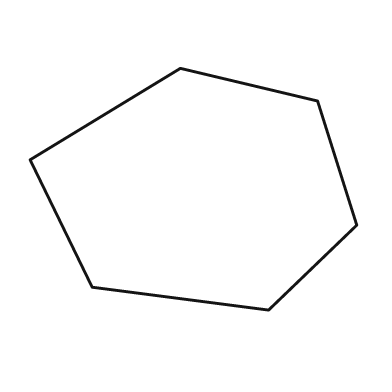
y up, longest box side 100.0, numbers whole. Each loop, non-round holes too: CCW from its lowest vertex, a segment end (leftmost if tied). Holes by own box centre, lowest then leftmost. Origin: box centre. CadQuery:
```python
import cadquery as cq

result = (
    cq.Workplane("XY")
    .moveTo(23.0, -37.0)
    .lineTo(50.0, -11.0)
    .lineTo(38.0, 27.0)
    .lineTo(-4.0, 37.0)
    .lineTo(-50.0, 9.0)
    .lineTo(-31.0, -30.0)
    .close()
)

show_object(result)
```